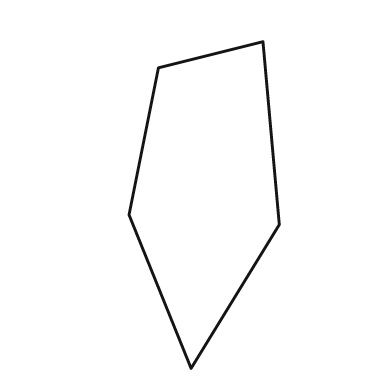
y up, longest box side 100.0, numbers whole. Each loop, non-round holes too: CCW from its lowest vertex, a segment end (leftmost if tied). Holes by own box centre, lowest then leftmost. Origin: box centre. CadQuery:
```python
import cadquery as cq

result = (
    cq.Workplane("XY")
    .moveTo(-4.0, -50.0)
    .lineTo(23.0, -6.0)
    .lineTo(18.0, 50.0)
    .lineTo(-14.0, 42.0)
    .lineTo(-23.0, -3.0)
    .close()
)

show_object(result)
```